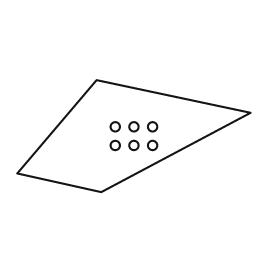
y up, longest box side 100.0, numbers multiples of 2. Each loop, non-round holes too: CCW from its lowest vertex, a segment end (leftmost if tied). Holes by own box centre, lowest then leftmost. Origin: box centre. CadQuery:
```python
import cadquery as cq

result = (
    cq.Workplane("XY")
    .moveTo(-14.0, -24.0)
    .lineTo(50.0, 10.0)
    .lineTo(-16.0, 24.0)
    .lineTo(-50.0, -16.0)
    .close()
    .moveTo(-8.0, -4.0)
    .circle(2.0)
    .moveTo(0.0, -4.0)
    .circle(2.0)
    .moveTo(8.0, -4.0)
    .circle(2.0)
    .moveTo(-8.0, 4.0)
    .circle(2.0)
    .moveTo(0.0, 4.0)
    .circle(2.0)
    .moveTo(8.0, 4.0)
    .circle(2.0)
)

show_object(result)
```